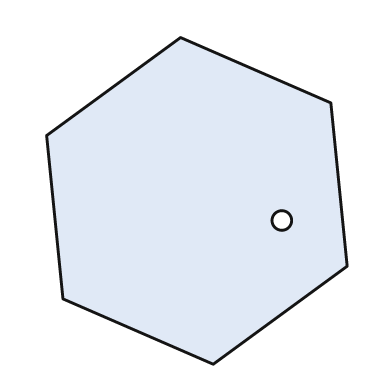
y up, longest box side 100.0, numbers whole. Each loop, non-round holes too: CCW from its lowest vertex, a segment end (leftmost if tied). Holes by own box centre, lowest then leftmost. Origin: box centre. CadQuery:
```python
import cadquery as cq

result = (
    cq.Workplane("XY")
    .moveTo(5.0, -50.0)
    .lineTo(46.0, -20.0)
    .lineTo(41.0, 30.0)
    .lineTo(-5.0, 50.0)
    .lineTo(-46.0, 20.0)
    .lineTo(-41.0, -30.0)
    .close()
    .moveTo(26.0, -6.0)
    .circle(3.0)
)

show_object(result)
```